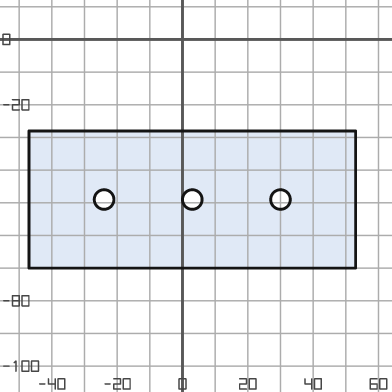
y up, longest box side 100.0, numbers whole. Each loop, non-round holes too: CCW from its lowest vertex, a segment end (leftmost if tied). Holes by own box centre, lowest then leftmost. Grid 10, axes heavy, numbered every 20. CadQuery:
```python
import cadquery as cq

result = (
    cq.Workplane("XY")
    .moveTo(-47.0, -70.0)
    .lineTo(53.0, -70.0)
    .lineTo(53.0, -28.0)
    .lineTo(-47.0, -28.0)
    .close()
    .moveTo(-24.0, -49.0)
    .circle(3.0)
    .moveTo(3.0, -49.0)
    .circle(3.0)
    .moveTo(30.0, -49.0)
    .circle(3.0)
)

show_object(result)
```